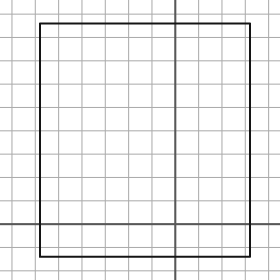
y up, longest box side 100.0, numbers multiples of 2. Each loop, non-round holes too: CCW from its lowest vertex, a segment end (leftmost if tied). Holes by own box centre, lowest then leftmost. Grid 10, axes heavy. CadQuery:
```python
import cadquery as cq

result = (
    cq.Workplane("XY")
    .moveTo(-58.0, -14.0)
    .lineTo(32.0, -14.0)
    .lineTo(32.0, 86.0)
    .lineTo(-58.0, 86.0)
    .close()
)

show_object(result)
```